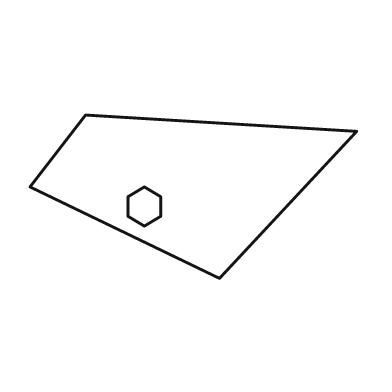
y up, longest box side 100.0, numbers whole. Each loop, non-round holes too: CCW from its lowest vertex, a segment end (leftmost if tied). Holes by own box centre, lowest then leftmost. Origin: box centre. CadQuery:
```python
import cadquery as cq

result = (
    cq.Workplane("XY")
    .moveTo(8.0, -25.0)
    .lineTo(50.0, 20.0)
    .lineTo(-33.0, 25.0)
    .lineTo(-50.0, 3.0)
    .close()
    .moveTo(-15.0, -9.0)
    .lineTo(-10.0, -6.0)
    .lineTo(-10.0, 0.0)
    .lineTo(-15.0, 3.0)
    .lineTo(-20.0, 0.0)
    .lineTo(-20.0, -6.0)
    .close()
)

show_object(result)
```